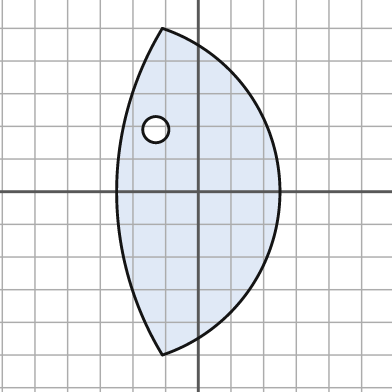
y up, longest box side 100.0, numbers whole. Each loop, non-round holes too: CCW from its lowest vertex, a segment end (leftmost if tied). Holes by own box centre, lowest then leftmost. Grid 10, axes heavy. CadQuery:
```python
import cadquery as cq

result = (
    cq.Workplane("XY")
    .moveTo(-11.0, -50.0)
    .threePointArc((25.0, 0.0), (-11.0, 50.0))
    .threePointArc((-25.0, 0.0), (-11.0, -50.0))
    .close()
    .moveTo(-13.0, 19.0)
    .circle(4.0)
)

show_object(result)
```